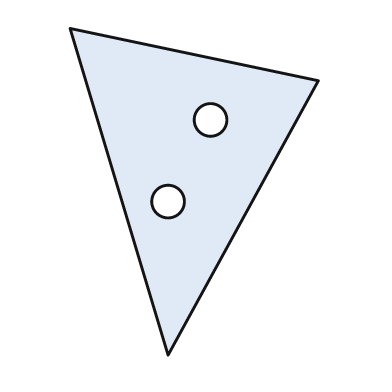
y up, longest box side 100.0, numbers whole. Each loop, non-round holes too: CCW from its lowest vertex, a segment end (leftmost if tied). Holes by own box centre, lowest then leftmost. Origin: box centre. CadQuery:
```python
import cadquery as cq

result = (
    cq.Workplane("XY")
    .moveTo(-8.0, -50.0)
    .lineTo(38.0, 34.0)
    .lineTo(-38.0, 50.0)
    .close()
    .moveTo(-8.0, -3.0)
    .circle(5.0)
    .moveTo(5.0, 22.0)
    .circle(5.0)
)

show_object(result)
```